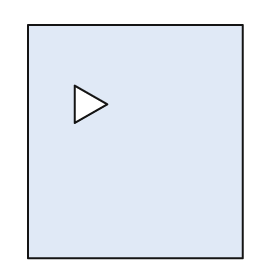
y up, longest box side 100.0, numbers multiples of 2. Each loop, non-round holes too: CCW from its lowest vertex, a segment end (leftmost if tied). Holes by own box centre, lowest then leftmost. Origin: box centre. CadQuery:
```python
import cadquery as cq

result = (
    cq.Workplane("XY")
    .moveTo(-46.0, -50.0)
    .lineTo(46.0, -50.0)
    .lineTo(46.0, 50.0)
    .lineTo(-46.0, 50.0)
    .close()
    .moveTo(-26.0, 8.0)
    .lineTo(-12.0, 16.0)
    .lineTo(-26.0, 24.0)
    .close()
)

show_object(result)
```